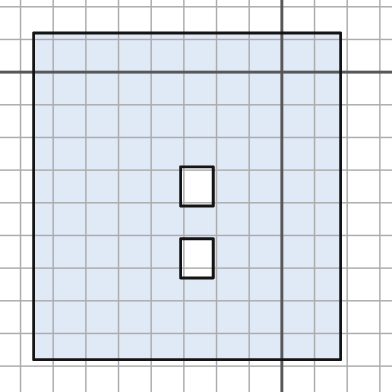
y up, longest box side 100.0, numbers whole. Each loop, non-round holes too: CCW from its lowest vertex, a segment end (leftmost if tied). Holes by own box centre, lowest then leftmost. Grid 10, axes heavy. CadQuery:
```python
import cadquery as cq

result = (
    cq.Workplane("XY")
    .moveTo(-76.0, -88.0)
    .lineTo(18.0, -88.0)
    .lineTo(18.0, 12.0)
    .lineTo(-76.0, 12.0)
    .close()
    .moveTo(-31.0, -63.0)
    .lineTo(-21.0, -63.0)
    .lineTo(-21.0, -51.0)
    .lineTo(-31.0, -51.0)
    .close()
    .moveTo(-31.0, -41.0)
    .lineTo(-21.0, -41.0)
    .lineTo(-21.0, -29.0)
    .lineTo(-31.0, -29.0)
    .close()
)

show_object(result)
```